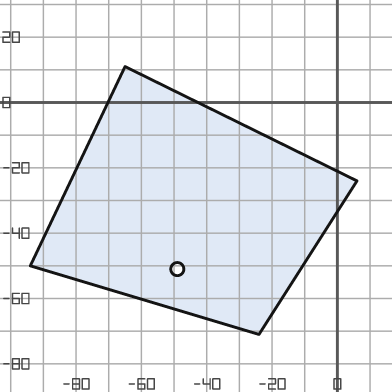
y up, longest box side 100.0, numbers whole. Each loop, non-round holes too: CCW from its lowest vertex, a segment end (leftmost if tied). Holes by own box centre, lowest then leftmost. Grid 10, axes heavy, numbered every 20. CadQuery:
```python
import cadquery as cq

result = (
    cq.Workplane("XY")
    .moveTo(-24.0, -71.0)
    .lineTo(6.0, -24.0)
    .lineTo(-65.0, 11.0)
    .lineTo(-94.0, -50.0)
    .close()
    .moveTo(-49.0, -51.0)
    .circle(2.0)
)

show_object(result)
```